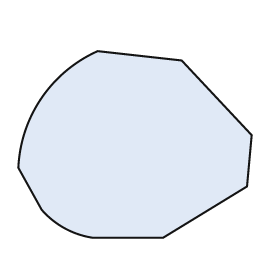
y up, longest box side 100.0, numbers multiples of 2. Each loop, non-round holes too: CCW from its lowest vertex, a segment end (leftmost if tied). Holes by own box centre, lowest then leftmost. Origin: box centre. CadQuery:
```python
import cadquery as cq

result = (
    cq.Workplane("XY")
    .moveTo(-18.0, -40.0)
    .lineTo(12.0, -40.0)
    .lineTo(48.0, -18.0)
    .lineTo(50.0, 4.0)
    .lineTo(20.0, 36.0)
    .lineTo(-16.0, 40.0)
    .threePointArc((-40.0, 20.0), (-50.0, -10.0))
    .lineTo(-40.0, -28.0)
    .threePointArc((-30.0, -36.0), (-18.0, -40.0))
    .close()
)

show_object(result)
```